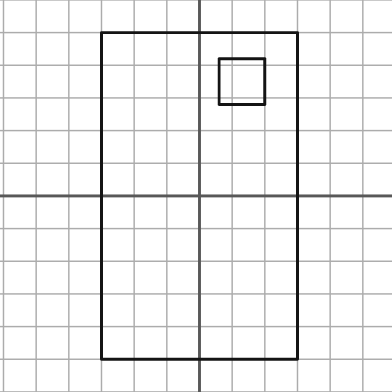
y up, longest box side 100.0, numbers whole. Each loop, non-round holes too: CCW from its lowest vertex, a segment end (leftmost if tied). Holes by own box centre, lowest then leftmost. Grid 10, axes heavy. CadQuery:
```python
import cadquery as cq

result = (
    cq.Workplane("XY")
    .moveTo(-30.0, -50.0)
    .lineTo(30.0, -50.0)
    .lineTo(30.0, 50.0)
    .lineTo(-30.0, 50.0)
    .close()
    .moveTo(6.0, 28.0)
    .lineTo(20.0, 28.0)
    .lineTo(20.0, 42.0)
    .lineTo(6.0, 42.0)
    .close()
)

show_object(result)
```